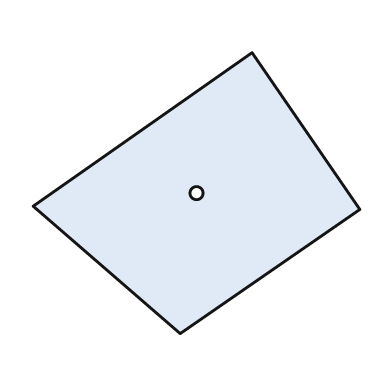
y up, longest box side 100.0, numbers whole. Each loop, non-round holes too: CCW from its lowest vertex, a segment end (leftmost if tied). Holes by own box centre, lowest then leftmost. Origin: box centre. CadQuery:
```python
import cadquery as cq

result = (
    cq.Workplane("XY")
    .moveTo(-5.0, -43.0)
    .lineTo(50.0, -5.0)
    .lineTo(17.0, 43.0)
    .lineTo(-50.0, -4.0)
    .close()
    .moveTo(0.0, 0.0)
    .circle(2.0)
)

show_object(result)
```